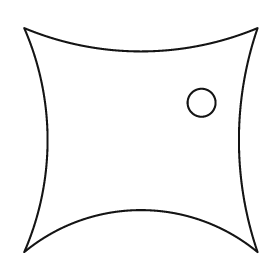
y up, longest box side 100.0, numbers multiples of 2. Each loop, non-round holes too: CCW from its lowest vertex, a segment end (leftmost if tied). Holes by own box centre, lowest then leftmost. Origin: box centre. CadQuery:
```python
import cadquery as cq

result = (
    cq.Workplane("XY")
    .moveTo(-50.0, -48.0)
    .threePointArc((0.0, -30.0), (50.0, -48.0))
    .threePointArc((42.0, 0.0), (50.0, 48.0))
    .threePointArc((0.0, 38.0), (-50.0, 48.0))
    .threePointArc((-40.0, 0.0), (-50.0, -48.0))
    .close()
    .moveTo(26.0, 16.0)
    .circle(6.0)
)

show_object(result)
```